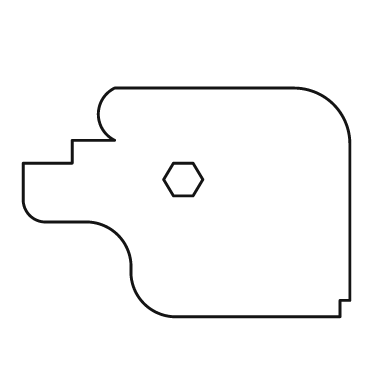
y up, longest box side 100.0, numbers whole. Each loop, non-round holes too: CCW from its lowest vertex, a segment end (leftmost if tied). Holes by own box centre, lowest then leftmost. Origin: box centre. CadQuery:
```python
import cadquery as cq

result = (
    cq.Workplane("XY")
    .moveTo(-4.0, -35.0)
    .lineTo(47.0, -35.0)
    .lineTo(47.0, -30.0)
    .lineTo(50.0, -30.0)
    .lineTo(50.0, 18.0)
    .threePointArc((45.0, 30.0), (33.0, 35.0))
    .lineTo(-22.0, 35.0)
    .threePointArc((-27.0, 27.0), (-22.0, 19.0))
    .lineTo(-35.0, 19.0)
    .lineTo(-35.0, 12.0)
    .lineTo(-50.0, 12.0)
    .lineTo(-50.0, 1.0)
    .threePointArc((-48.0, -4.0), (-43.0, -6.0))
    .lineTo(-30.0, -6.0)
    .threePointArc((-21.0, -10.0), (-17.0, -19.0))
    .lineTo(-17.0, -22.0)
    .threePointArc((-13.0, -31.0), (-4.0, -35.0))
    .close()
    .moveTo(-4.0, 2.0)
    .lineTo(2.0, 2.0)
    .lineTo(5.0, 7.0)
    .lineTo(2.0, 12.0)
    .lineTo(-4.0, 12.0)
    .lineTo(-7.0, 7.0)
    .close()
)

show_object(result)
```